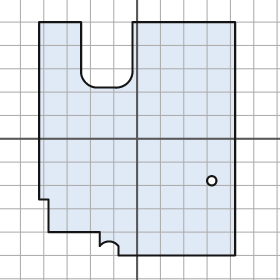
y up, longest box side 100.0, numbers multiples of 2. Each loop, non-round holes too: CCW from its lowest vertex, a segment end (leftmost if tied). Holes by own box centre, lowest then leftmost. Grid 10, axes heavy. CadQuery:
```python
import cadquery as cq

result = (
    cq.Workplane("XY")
    .moveTo(-8.0, -50.0)
    .lineTo(42.0, -50.0)
    .lineTo(42.0, 50.0)
    .lineTo(-2.0, 50.0)
    .lineTo(-2.0, 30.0)
    .threePointArc((-4.0, 24.0), (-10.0, 22.0))
    .lineTo(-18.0, 22.0)
    .threePointArc((-22.0, 24.0), (-24.0, 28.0))
    .lineTo(-24.0, 50.0)
    .lineTo(-42.0, 50.0)
    .lineTo(-42.0, -26.0)
    .lineTo(-38.0, -26.0)
    .lineTo(-38.0, -40.0)
    .lineTo(-16.0, -40.0)
    .lineTo(-16.0, -46.0)
    .threePointArc((-12.0, -44.0), (-8.0, -46.0))
    .close()
    .moveTo(32.0, -18.0)
    .circle(2.0)
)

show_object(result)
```